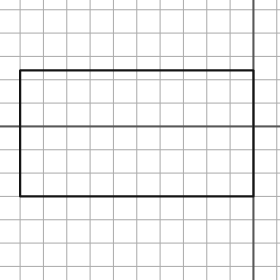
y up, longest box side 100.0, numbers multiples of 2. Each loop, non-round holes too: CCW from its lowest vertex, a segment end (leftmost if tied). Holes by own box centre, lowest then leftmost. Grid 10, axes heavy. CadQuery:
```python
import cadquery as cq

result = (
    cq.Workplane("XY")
    .moveTo(-100.0, -30.0)
    .lineTo(0.0, -30.0)
    .lineTo(0.0, 24.0)
    .lineTo(-100.0, 24.0)
    .close()
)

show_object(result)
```